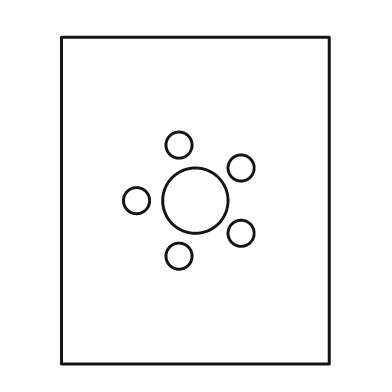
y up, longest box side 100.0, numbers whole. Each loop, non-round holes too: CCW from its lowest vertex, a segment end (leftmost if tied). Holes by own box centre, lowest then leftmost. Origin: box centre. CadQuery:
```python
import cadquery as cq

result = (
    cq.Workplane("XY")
    .moveTo(-41.0, -50.0)
    .lineTo(41.0, -50.0)
    .lineTo(41.0, 50.0)
    .lineTo(-41.0, 50.0)
    .close()
    .moveTo(-5.0, -17.0)
    .circle(4.0)
    .moveTo(14.0, -10.0)
    .circle(4.0)
    .moveTo(-18.0, 0.0)
    .circle(4.0)
    .moveTo(0.0, 0.0)
    .circle(10.0)
    .moveTo(14.0, 10.0)
    .circle(4.0)
    .moveTo(-5.0, 17.0)
    .circle(4.0)
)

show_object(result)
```